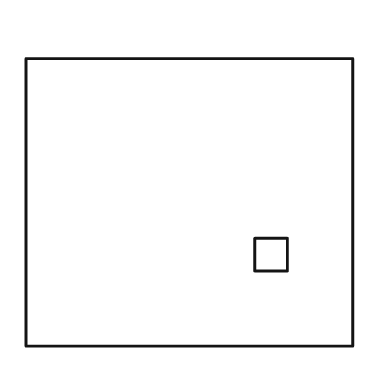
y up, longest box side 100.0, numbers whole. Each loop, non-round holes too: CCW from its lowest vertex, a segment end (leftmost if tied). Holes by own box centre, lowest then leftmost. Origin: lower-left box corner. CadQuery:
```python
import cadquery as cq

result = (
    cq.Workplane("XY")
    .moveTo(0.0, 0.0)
    .lineTo(100.0, 0.0)
    .lineTo(100.0, 88.0)
    .lineTo(0.0, 88.0)
    .close()
    .moveTo(70.0, 23.0)
    .lineTo(80.0, 23.0)
    .lineTo(80.0, 33.0)
    .lineTo(70.0, 33.0)
    .close()
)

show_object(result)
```